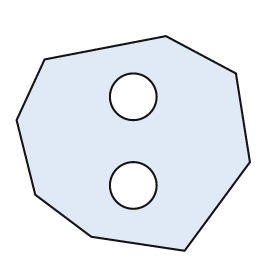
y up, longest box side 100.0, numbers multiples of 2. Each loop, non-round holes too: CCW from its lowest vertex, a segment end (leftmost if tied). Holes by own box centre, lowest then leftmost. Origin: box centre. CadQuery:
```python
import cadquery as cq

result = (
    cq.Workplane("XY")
    .moveTo(22.0, -46.0)
    .lineTo(50.0, -8.0)
    .lineTo(44.0, 30.0)
    .lineTo(14.0, 46.0)
    .lineTo(-38.0, 36.0)
    .lineTo(-50.0, 10.0)
    .lineTo(-42.0, -22.0)
    .lineTo(-18.0, -40.0)
    .close()
    .moveTo(0.0, -18.0)
    .circle(10.0)
    .moveTo(0.0, 20.0)
    .circle(10.0)
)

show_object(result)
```